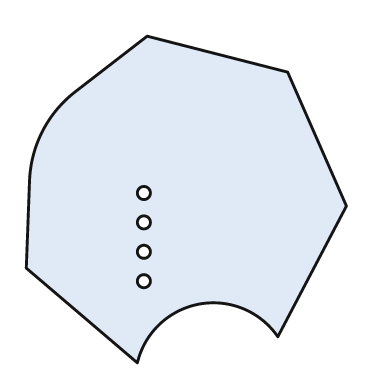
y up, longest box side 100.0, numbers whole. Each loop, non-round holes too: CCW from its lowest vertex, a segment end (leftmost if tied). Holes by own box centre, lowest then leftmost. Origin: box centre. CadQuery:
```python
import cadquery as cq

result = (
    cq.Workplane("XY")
    .moveTo(-15.0, -50.0)
    .threePointArc((4.0, -32.0), (28.0, -42.0))
    .lineTo(49.0, -2.0)
    .lineTo(31.0, 39.0)
    .lineTo(-12.0, 50.0)
    .lineTo(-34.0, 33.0)
    .threePointArc((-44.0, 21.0), (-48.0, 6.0))
    .lineTo(-49.0, -21.0)
    .close()
    .moveTo(-13.0, -25.0)
    .circle(2.0)
    .moveTo(-13.0, -16.0)
    .circle(2.0)
    .moveTo(-13.0, -7.0)
    .circle(2.0)
    .moveTo(-13.0, 2.0)
    .circle(2.0)
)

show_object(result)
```